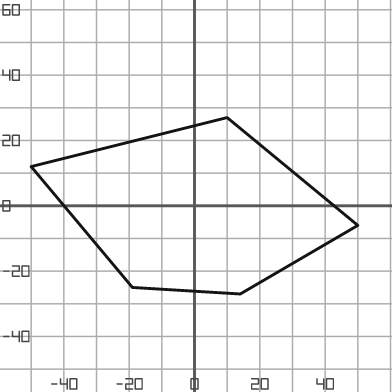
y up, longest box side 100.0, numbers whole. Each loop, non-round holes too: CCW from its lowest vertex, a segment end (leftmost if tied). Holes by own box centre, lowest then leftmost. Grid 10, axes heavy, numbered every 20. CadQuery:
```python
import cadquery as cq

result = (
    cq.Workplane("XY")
    .moveTo(14.0, -27.0)
    .lineTo(50.0, -6.0)
    .lineTo(10.0, 27.0)
    .lineTo(-50.0, 12.0)
    .lineTo(-19.0, -25.0)
    .close()
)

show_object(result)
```